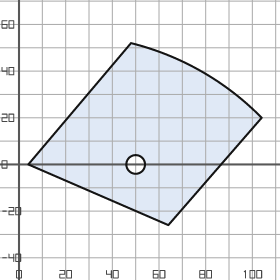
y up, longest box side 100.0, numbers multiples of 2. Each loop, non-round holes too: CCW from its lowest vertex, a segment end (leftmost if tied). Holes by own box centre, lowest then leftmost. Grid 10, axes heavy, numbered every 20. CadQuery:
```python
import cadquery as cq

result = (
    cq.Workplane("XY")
    .moveTo(64.0, -26.0)
    .lineTo(104.0, 20.0)
    .threePointArc((78.0, 40.0), (48.0, 52.0))
    .lineTo(4.0, 0.0)
    .close()
    .moveTo(50.0, 0.0)
    .circle(4.0)
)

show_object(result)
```